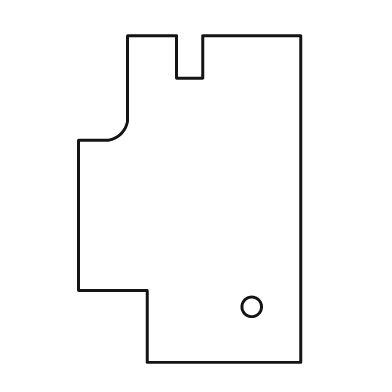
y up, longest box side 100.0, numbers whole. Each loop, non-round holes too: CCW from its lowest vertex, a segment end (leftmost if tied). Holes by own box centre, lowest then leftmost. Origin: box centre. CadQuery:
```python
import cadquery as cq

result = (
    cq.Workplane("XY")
    .moveTo(-13.0, -50.0)
    .lineTo(34.0, -50.0)
    .lineTo(34.0, 50.0)
    .lineTo(4.0, 50.0)
    .lineTo(4.0, 37.0)
    .lineTo(-4.0, 37.0)
    .lineTo(-4.0, 50.0)
    .lineTo(-19.0, 50.0)
    .lineTo(-19.0, 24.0)
    .threePointArc((-21.0, 20.0), (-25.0, 18.0))
    .lineTo(-34.0, 18.0)
    .lineTo(-34.0, -28.0)
    .lineTo(-13.0, -28.0)
    .close()
    .moveTo(19.0, -33.0)
    .circle(3.0)
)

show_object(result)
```